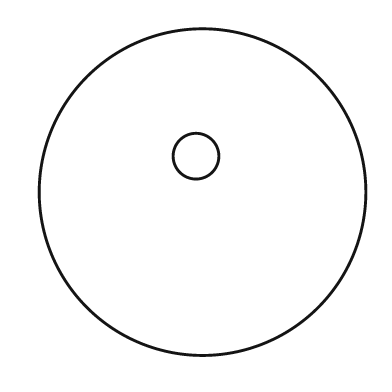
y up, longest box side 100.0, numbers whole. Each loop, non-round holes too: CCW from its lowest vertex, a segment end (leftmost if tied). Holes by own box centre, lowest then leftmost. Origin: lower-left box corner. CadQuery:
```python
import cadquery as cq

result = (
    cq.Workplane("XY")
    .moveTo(50.0, 50.0)
    .circle(50.0)
    .moveTo(48.0, 61.0)
    .circle(7.0)
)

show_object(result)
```